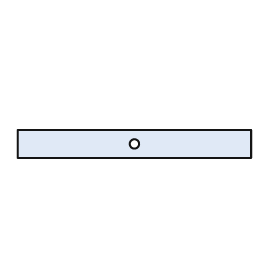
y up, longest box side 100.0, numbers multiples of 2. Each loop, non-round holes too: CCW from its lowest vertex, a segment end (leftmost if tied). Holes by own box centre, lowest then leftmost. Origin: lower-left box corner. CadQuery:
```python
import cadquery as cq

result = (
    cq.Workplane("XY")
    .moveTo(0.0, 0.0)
    .lineTo(100.0, 0.0)
    .lineTo(100.0, 12.0)
    .lineTo(0.0, 12.0)
    .close()
    .moveTo(50.0, 6.0)
    .circle(2.0)
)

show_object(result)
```